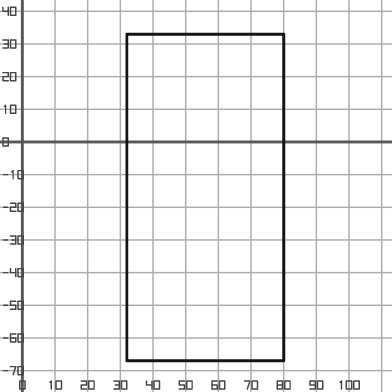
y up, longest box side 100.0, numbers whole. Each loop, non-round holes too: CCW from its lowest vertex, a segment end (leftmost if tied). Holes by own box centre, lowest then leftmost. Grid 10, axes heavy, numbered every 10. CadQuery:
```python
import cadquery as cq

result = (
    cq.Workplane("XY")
    .moveTo(32.0, -67.0)
    .lineTo(80.0, -67.0)
    .lineTo(80.0, 33.0)
    .lineTo(32.0, 33.0)
    .close()
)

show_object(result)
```